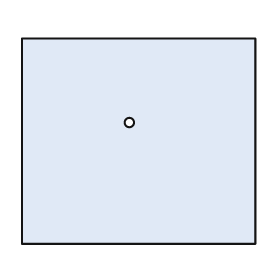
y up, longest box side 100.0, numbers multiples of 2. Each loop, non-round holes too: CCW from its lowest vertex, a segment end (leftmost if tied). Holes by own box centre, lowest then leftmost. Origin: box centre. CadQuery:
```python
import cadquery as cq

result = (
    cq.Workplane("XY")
    .moveTo(-50.0, -44.0)
    .lineTo(50.0, -44.0)
    .lineTo(50.0, 44.0)
    .lineTo(-50.0, 44.0)
    .close()
    .moveTo(-4.0, 8.0)
    .circle(2.0)
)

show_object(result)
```